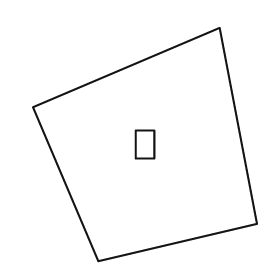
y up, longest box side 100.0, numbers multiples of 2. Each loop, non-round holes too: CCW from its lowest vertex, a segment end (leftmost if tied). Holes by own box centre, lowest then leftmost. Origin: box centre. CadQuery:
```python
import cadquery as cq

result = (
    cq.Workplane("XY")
    .moveTo(-20.0, -50.0)
    .lineTo(48.0, -34.0)
    .lineTo(32.0, 50.0)
    .lineTo(-48.0, 16.0)
    .close()
    .moveTo(-4.0, -6.0)
    .lineTo(4.0, -6.0)
    .lineTo(4.0, 6.0)
    .lineTo(-4.0, 6.0)
    .close()
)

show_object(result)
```